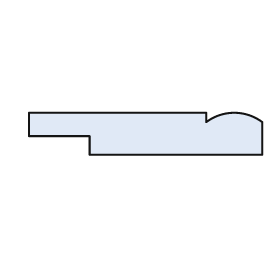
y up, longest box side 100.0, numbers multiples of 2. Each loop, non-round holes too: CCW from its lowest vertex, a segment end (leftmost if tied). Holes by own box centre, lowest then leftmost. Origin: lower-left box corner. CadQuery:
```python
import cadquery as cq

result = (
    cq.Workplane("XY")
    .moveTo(26.0, 0.0)
    .lineTo(100.0, 0.0)
    .lineTo(100.0, 14.0)
    .threePointArc((88.0, 18.0), (76.0, 14.0))
    .lineTo(76.0, 18.0)
    .lineTo(0.0, 18.0)
    .lineTo(0.0, 8.0)
    .lineTo(26.0, 8.0)
    .close()
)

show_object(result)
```